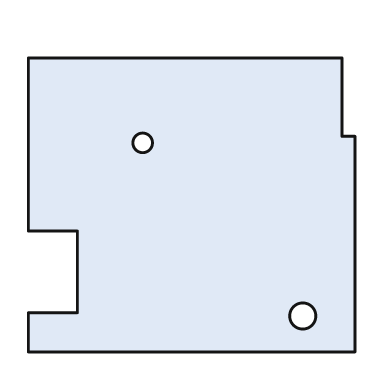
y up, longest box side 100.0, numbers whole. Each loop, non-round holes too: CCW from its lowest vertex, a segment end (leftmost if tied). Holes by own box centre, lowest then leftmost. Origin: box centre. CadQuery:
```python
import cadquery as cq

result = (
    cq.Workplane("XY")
    .moveTo(-50.0, -45.0)
    .lineTo(50.0, -45.0)
    .lineTo(50.0, 21.0)
    .lineTo(46.0, 21.0)
    .lineTo(46.0, 45.0)
    .lineTo(-50.0, 45.0)
    .lineTo(-50.0, -8.0)
    .lineTo(-35.0, -8.0)
    .lineTo(-35.0, -33.0)
    .lineTo(-50.0, -33.0)
    .close()
    .moveTo(34.0, -34.0)
    .circle(4.0)
    .moveTo(-15.0, 19.0)
    .circle(3.0)
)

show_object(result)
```